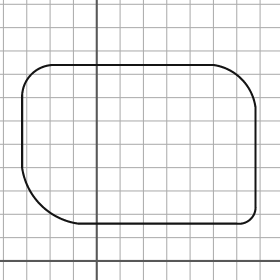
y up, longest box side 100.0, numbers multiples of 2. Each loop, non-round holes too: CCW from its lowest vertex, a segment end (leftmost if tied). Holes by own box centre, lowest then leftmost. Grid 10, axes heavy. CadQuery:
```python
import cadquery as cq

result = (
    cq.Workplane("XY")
    .moveTo(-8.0, 16.0)
    .lineTo(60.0, 16.0)
    .threePointArc((66.0, 18.0), (68.0, 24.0))
    .lineTo(68.0, 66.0)
    .threePointArc((62.0, 78.0), (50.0, 84.0))
    .lineTo(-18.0, 84.0)
    .threePointArc((-28.0, 80.0), (-32.0, 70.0))
    .lineTo(-32.0, 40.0)
    .threePointArc((-24.0, 24.0), (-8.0, 16.0))
    .close()
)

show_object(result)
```